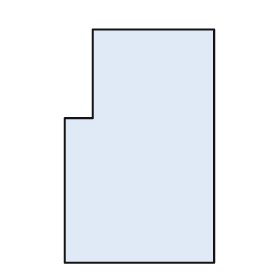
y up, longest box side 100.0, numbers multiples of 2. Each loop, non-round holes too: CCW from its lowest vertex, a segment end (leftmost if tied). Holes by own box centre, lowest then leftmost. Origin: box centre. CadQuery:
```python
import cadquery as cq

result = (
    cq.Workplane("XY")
    .moveTo(-32.0, -50.0)
    .lineTo(32.0, -50.0)
    .lineTo(32.0, 50.0)
    .lineTo(-20.0, 50.0)
    .lineTo(-20.0, 12.0)
    .lineTo(-32.0, 12.0)
    .close()
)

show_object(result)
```